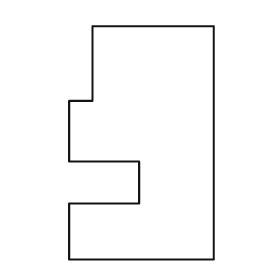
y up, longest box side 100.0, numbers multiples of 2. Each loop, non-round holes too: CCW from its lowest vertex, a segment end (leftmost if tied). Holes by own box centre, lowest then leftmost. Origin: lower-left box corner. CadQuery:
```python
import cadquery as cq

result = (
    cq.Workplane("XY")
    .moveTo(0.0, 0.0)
    .lineTo(62.0, 0.0)
    .lineTo(62.0, 100.0)
    .lineTo(10.0, 100.0)
    .lineTo(10.0, 68.0)
    .lineTo(0.0, 68.0)
    .lineTo(0.0, 42.0)
    .lineTo(30.0, 42.0)
    .lineTo(30.0, 24.0)
    .lineTo(0.0, 24.0)
    .close()
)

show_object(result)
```